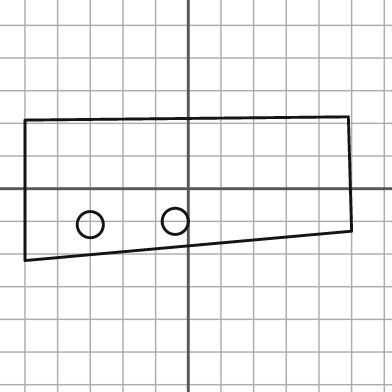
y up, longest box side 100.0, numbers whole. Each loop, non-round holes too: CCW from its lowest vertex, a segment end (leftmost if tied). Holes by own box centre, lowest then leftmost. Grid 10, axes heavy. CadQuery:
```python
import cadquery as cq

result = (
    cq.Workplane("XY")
    .moveTo(-50.0, -22.0)
    .lineTo(50.0, -13.0)
    .lineTo(49.0, 22.0)
    .lineTo(-50.0, 21.0)
    .close()
    .moveTo(-30.0, -11.0)
    .circle(4.0)
    .moveTo(-4.0, -10.0)
    .circle(4.0)
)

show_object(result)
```